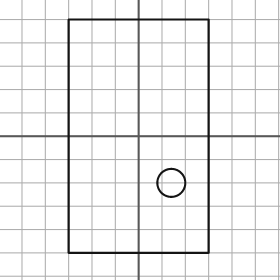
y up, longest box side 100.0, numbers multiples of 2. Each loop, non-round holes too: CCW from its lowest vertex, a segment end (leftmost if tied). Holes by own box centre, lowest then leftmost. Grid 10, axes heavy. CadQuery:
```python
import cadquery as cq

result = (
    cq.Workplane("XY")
    .moveTo(-30.0, -50.0)
    .lineTo(30.0, -50.0)
    .lineTo(30.0, 50.0)
    .lineTo(-30.0, 50.0)
    .close()
    .moveTo(14.0, -20.0)
    .circle(6.0)
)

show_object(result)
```